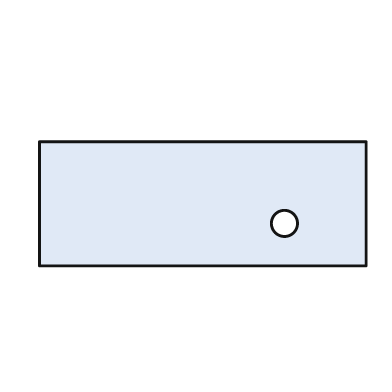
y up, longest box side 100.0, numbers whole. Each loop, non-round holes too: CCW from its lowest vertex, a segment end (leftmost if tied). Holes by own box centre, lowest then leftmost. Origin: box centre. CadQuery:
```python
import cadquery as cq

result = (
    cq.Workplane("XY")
    .moveTo(-50.0, -19.0)
    .lineTo(50.0, -19.0)
    .lineTo(50.0, 19.0)
    .lineTo(-50.0, 19.0)
    .close()
    .moveTo(25.0, -6.0)
    .circle(4.0)
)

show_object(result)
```